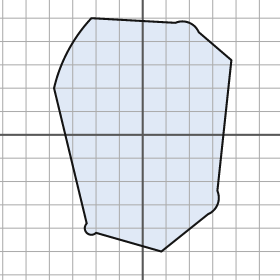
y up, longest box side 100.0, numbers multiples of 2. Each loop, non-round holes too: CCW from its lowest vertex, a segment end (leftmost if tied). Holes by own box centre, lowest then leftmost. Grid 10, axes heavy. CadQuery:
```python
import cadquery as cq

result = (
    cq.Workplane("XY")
    .moveTo(8.0, -50.0)
    .lineTo(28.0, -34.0)
    .threePointArc((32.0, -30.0), (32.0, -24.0))
    .lineTo(38.0, 32.0)
    .lineTo(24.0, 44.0)
    .threePointArc((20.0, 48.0), (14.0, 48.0))
    .lineTo(-22.0, 50.0)
    .threePointArc((-32.0, 36.0), (-38.0, 20.0))
    .lineTo(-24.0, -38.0)
    .threePointArc((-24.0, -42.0), (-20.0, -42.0))
    .close()
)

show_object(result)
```